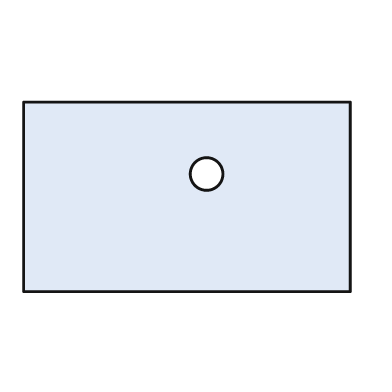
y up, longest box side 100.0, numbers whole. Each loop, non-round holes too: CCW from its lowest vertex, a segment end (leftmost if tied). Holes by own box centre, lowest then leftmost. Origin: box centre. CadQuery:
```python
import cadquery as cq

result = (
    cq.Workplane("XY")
    .moveTo(-50.0, -29.0)
    .lineTo(50.0, -29.0)
    .lineTo(50.0, 29.0)
    .lineTo(-50.0, 29.0)
    .close()
    .moveTo(6.0, 7.0)
    .circle(5.0)
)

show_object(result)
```